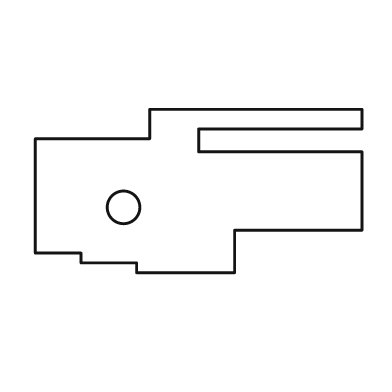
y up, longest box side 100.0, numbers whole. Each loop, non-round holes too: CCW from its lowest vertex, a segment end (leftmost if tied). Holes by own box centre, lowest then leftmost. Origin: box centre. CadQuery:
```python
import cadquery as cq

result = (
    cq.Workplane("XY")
    .moveTo(-19.0, -25.0)
    .lineTo(11.0, -25.0)
    .lineTo(11.0, -12.0)
    .lineTo(50.0, -12.0)
    .lineTo(50.0, 12.0)
    .lineTo(0.0, 12.0)
    .lineTo(0.0, 19.0)
    .lineTo(50.0, 19.0)
    .lineTo(50.0, 25.0)
    .lineTo(-15.0, 25.0)
    .lineTo(-15.0, 16.0)
    .lineTo(-50.0, 16.0)
    .lineTo(-50.0, -19.0)
    .lineTo(-36.0, -19.0)
    .lineTo(-36.0, -22.0)
    .lineTo(-19.0, -22.0)
    .close()
    .moveTo(-23.0, -5.0)
    .circle(5.0)
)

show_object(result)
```